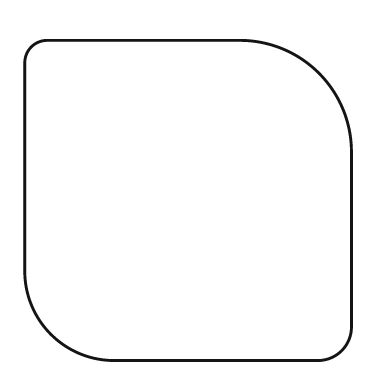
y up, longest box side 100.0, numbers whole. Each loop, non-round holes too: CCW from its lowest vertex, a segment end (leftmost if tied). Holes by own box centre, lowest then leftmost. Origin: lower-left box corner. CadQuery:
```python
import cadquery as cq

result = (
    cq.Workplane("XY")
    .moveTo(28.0, 0.0)
    .lineTo(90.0, 0.0)
    .threePointArc((97.0, 3.0), (100.0, 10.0))
    .lineTo(100.0, 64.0)
    .threePointArc((90.0, 88.0), (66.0, 98.0))
    .lineTo(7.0, 98.0)
    .threePointArc((2.0, 96.0), (0.0, 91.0))
    .lineTo(0.0, 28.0)
    .threePointArc((8.0, 8.0), (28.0, 0.0))
    .close()
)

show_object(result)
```